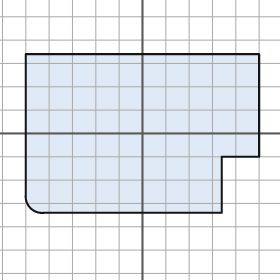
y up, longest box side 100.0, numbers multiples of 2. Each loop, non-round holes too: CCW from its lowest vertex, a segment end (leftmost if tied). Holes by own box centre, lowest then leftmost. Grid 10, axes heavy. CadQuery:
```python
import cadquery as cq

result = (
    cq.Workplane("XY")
    .moveTo(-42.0, -34.0)
    .lineTo(34.0, -34.0)
    .lineTo(34.0, -10.0)
    .lineTo(50.0, -10.0)
    .lineTo(50.0, 34.0)
    .lineTo(-50.0, 34.0)
    .lineTo(-50.0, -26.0)
    .threePointArc((-48.0, -32.0), (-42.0, -34.0))
    .close()
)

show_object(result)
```